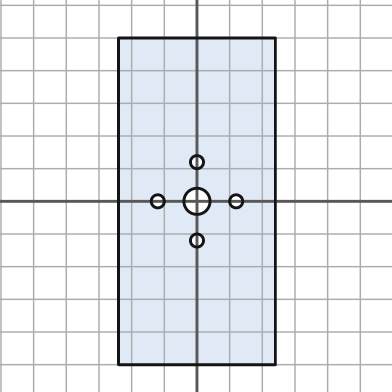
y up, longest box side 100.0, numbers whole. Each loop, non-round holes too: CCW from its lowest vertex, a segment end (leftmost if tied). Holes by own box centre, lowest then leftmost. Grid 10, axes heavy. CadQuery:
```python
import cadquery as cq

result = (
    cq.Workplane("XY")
    .moveTo(-24.0, -50.0)
    .lineTo(24.0, -50.0)
    .lineTo(24.0, 50.0)
    .lineTo(-24.0, 50.0)
    .close()
    .moveTo(0.0, -12.0)
    .circle(2.0)
    .moveTo(-12.0, 0.0)
    .circle(2.0)
    .moveTo(0.0, 0.0)
    .circle(4.0)
    .moveTo(12.0, 0.0)
    .circle(2.0)
    .moveTo(0.0, 12.0)
    .circle(2.0)
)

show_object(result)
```